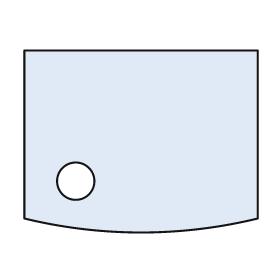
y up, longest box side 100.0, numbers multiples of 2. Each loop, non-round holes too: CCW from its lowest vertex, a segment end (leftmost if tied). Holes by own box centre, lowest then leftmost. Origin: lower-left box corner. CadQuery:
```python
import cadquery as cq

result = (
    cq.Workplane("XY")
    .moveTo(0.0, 6.0)
    .threePointArc((50.0, 0.0), (100.0, 6.0))
    .lineTo(100.0, 78.0)
    .lineTo(0.0, 78.0)
    .close()
    .moveTo(22.0, 22.0)
    .circle(8.0)
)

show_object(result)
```